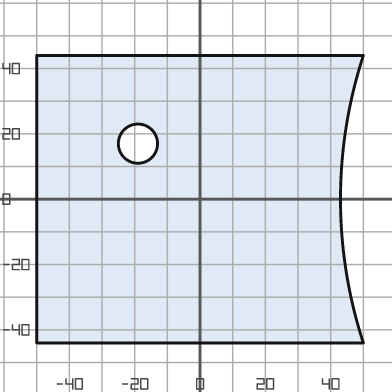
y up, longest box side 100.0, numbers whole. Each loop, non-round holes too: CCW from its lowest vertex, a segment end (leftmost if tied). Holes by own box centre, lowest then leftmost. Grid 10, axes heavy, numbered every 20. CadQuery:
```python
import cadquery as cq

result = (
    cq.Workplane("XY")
    .moveTo(-50.0, -44.0)
    .lineTo(50.0, -44.0)
    .threePointArc((43.0, 0.0), (50.0, 44.0))
    .lineTo(-50.0, 44.0)
    .close()
    .moveTo(-19.0, 17.0)
    .circle(6.0)
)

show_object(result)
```